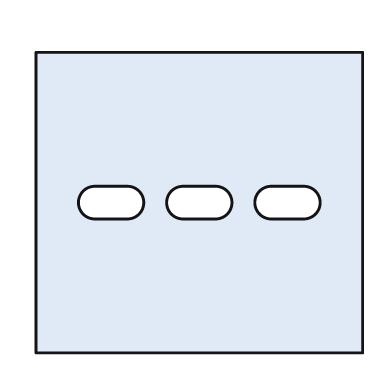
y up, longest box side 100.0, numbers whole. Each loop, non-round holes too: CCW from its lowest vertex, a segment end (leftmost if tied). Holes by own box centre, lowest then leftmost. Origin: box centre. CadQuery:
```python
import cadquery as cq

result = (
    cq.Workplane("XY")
    .moveTo(-50.0, -46.0)
    .lineTo(50.0, -46.0)
    .lineTo(50.0, 46.0)
    .lineTo(-50.0, 46.0)
    .close()
    .moveTo(-32.0, -5.0)
    .lineTo(-22.0, -5.0)
    .threePointArc((-17.0, 0.0), (-22.0, 5.0))
    .lineTo(-32.0, 5.0)
    .threePointArc((-37.0, 0.0), (-32.0, -5.0))
    .close()
    .moveTo(-5.0, -5.0)
    .lineTo(5.0, -5.0)
    .threePointArc((10.0, 0.0), (5.0, 5.0))
    .lineTo(-5.0, 5.0)
    .threePointArc((-10.0, 0.0), (-5.0, -5.0))
    .close()
    .moveTo(22.0, -5.0)
    .lineTo(32.0, -5.0)
    .threePointArc((37.0, 0.0), (32.0, 5.0))
    .lineTo(22.0, 5.0)
    .threePointArc((17.0, 0.0), (22.0, -5.0))
    .close()
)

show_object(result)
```